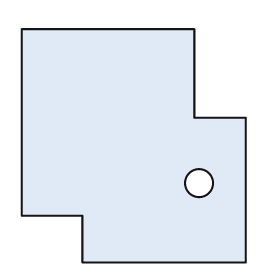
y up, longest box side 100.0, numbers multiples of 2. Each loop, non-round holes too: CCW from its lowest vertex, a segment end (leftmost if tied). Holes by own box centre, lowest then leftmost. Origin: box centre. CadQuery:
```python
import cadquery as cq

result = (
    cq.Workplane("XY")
    .moveTo(-22.0, -50.0)
    .lineTo(48.0, -50.0)
    .lineTo(48.0, 12.0)
    .lineTo(26.0, 12.0)
    .lineTo(26.0, 50.0)
    .lineTo(-48.0, 50.0)
    .lineTo(-48.0, -30.0)
    .lineTo(-22.0, -30.0)
    .close()
    .moveTo(28.0, -16.0)
    .circle(6.0)
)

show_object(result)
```